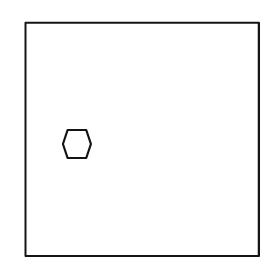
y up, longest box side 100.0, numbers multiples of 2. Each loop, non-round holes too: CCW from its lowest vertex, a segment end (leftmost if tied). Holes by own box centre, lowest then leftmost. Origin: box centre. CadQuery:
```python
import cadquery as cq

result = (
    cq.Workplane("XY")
    .moveTo(-50.0, -50.0)
    .lineTo(50.0, -50.0)
    .lineTo(50.0, 50.0)
    .lineTo(-50.0, 50.0)
    .close()
    .moveTo(-32.0, -8.0)
    .lineTo(-24.0, -8.0)
    .lineTo(-22.0, -2.0)
    .lineTo(-24.0, 4.0)
    .lineTo(-32.0, 4.0)
    .lineTo(-34.0, -2.0)
    .close()
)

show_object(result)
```